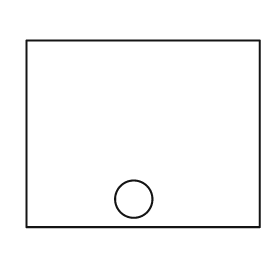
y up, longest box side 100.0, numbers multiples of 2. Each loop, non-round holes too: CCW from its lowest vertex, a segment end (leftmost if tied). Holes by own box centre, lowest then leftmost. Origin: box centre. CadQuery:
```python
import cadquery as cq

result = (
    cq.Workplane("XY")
    .moveTo(-50.0, -40.0)
    .lineTo(50.0, -40.0)
    .lineTo(50.0, 40.0)
    .lineTo(-50.0, 40.0)
    .close()
    .moveTo(-4.0, -28.0)
    .circle(8.0)
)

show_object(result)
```